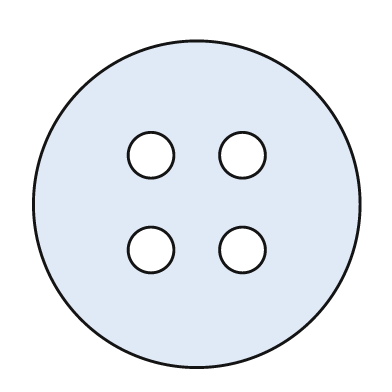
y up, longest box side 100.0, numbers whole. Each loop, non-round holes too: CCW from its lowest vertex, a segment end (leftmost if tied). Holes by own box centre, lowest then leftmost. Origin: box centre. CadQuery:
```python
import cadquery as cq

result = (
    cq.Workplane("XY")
    .moveTo(0.0, 0.0)
    .circle(50.0)
    .moveTo(-14.0, -14.0)
    .circle(7.0)
    .moveTo(14.0, -14.0)
    .circle(7.0)
    .moveTo(-14.0, 15.0)
    .circle(7.0)
    .moveTo(14.0, 15.0)
    .circle(7.0)
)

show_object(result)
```